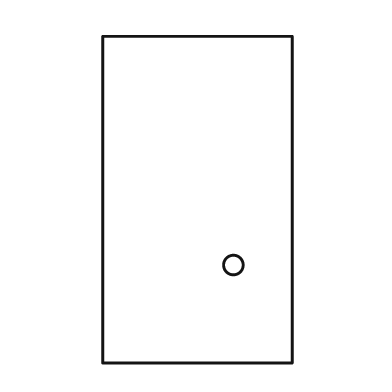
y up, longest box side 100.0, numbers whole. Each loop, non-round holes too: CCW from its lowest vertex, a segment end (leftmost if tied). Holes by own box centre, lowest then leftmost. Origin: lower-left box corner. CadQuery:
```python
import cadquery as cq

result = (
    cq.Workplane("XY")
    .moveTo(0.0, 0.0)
    .lineTo(58.0, 0.0)
    .lineTo(58.0, 100.0)
    .lineTo(0.0, 100.0)
    .close()
    .moveTo(40.0, 30.0)
    .circle(3.0)
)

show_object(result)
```